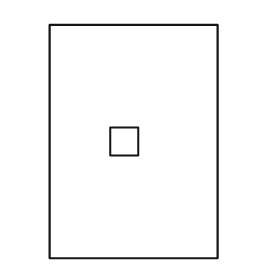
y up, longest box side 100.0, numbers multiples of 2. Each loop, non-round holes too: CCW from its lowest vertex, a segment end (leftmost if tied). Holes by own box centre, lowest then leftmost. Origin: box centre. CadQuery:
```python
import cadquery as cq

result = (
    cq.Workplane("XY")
    .moveTo(-36.0, -50.0)
    .lineTo(36.0, -50.0)
    .lineTo(36.0, 50.0)
    .lineTo(-36.0, 50.0)
    .close()
    .moveTo(-10.0, -6.0)
    .lineTo(2.0, -6.0)
    .lineTo(2.0, 6.0)
    .lineTo(-10.0, 6.0)
    .close()
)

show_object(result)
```